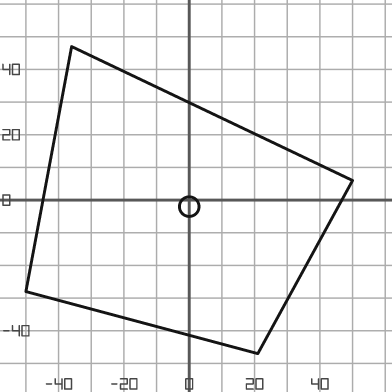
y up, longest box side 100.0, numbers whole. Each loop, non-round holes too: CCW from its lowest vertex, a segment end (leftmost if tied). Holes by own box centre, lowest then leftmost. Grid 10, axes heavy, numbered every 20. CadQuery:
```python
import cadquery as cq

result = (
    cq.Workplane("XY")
    .moveTo(21.0, -47.0)
    .lineTo(50.0, 6.0)
    .lineTo(-36.0, 47.0)
    .lineTo(-50.0, -28.0)
    .close()
    .moveTo(0.0, -2.0)
    .circle(3.0)
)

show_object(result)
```